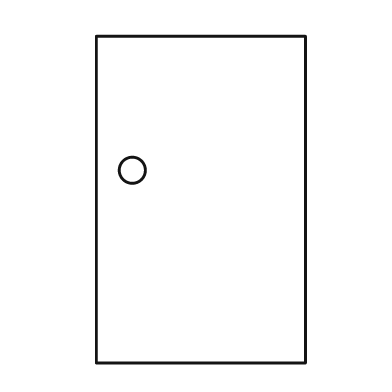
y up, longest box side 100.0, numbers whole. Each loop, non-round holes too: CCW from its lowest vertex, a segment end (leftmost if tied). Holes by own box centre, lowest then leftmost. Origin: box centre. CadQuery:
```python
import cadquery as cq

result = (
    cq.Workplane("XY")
    .moveTo(-32.0, -50.0)
    .lineTo(32.0, -50.0)
    .lineTo(32.0, 50.0)
    .lineTo(-32.0, 50.0)
    .close()
    .moveTo(-21.0, 9.0)
    .circle(4.0)
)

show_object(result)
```